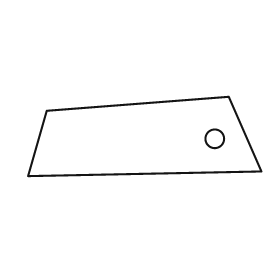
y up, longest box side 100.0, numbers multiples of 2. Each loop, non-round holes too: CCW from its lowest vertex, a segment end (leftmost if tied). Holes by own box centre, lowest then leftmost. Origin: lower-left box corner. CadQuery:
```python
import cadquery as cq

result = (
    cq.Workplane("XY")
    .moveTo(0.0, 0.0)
    .lineTo(100.0, 2.0)
    .lineTo(86.0, 34.0)
    .lineTo(8.0, 28.0)
    .close()
    .moveTo(80.0, 16.0)
    .circle(4.0)
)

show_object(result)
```